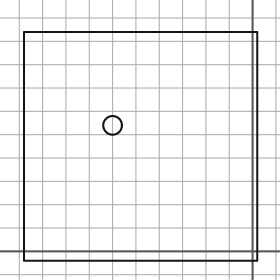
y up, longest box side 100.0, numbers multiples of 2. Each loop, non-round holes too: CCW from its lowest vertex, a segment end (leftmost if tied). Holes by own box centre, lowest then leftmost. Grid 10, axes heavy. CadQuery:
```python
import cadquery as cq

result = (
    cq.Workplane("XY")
    .moveTo(-98.0, -4.0)
    .lineTo(2.0, -4.0)
    .lineTo(2.0, 94.0)
    .lineTo(-98.0, 94.0)
    .close()
    .moveTo(-60.0, 54.0)
    .circle(4.0)
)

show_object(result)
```